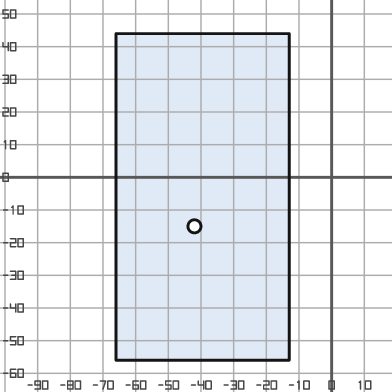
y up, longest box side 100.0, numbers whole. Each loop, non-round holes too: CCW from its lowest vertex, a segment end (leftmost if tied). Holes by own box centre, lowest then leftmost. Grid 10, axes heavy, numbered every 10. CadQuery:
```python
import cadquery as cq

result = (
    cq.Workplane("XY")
    .moveTo(-66.0, -56.0)
    .lineTo(-13.0, -56.0)
    .lineTo(-13.0, 44.0)
    .lineTo(-66.0, 44.0)
    .close()
    .moveTo(-42.0, -15.0)
    .circle(2.0)
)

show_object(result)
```